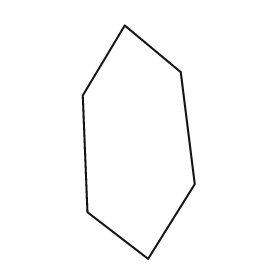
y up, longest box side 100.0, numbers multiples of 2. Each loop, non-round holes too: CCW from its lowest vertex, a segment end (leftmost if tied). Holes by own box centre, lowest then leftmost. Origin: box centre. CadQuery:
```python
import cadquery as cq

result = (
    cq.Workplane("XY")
    .moveTo(4.0, -50.0)
    .lineTo(24.0, -18.0)
    .lineTo(18.0, 30.0)
    .lineTo(-6.0, 50.0)
    .lineTo(-24.0, 20.0)
    .lineTo(-22.0, -30.0)
    .close()
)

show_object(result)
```